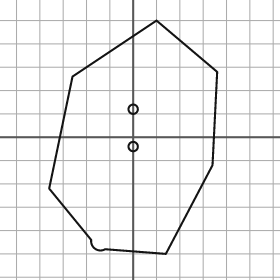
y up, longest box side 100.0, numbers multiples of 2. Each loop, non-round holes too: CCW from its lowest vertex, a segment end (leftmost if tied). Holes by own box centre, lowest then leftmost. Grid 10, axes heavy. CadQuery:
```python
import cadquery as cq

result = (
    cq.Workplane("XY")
    .moveTo(14.0, -50.0)
    .lineTo(34.0, -12.0)
    .lineTo(36.0, 28.0)
    .lineTo(10.0, 50.0)
    .lineTo(-26.0, 26.0)
    .lineTo(-36.0, -22.0)
    .lineTo(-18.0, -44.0)
    .threePointArc((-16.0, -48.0), (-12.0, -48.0))
    .close()
    .moveTo(0.0, -4.0)
    .circle(2.0)
    .moveTo(0.0, 12.0)
    .circle(2.0)
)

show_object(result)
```